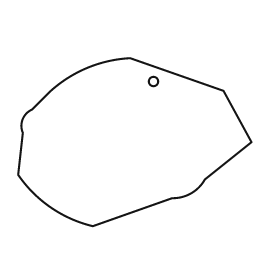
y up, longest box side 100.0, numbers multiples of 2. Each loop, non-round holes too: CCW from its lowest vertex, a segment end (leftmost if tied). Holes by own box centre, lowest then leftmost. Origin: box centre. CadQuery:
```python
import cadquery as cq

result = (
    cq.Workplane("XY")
    .moveTo(-18.0, -36.0)
    .lineTo(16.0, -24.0)
    .threePointArc((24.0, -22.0), (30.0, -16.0))
    .lineTo(50.0, 0.0)
    .lineTo(38.0, 22.0)
    .lineTo(-2.0, 36.0)
    .threePointArc((-20.0, 32.0), (-36.0, 22.0))
    .lineTo(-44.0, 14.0)
    .threePointArc((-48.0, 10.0), (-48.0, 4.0))
    .lineTo(-50.0, -14.0)
    .threePointArc((-36.0, -28.0), (-18.0, -36.0))
    .close()
    .moveTo(8.0, 26.0)
    .circle(2.0)
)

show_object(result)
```